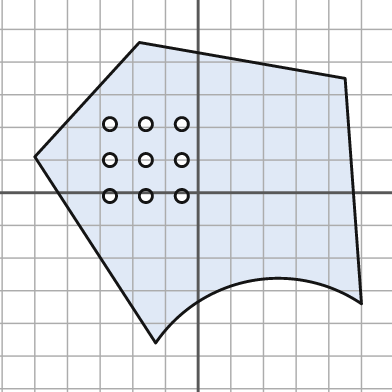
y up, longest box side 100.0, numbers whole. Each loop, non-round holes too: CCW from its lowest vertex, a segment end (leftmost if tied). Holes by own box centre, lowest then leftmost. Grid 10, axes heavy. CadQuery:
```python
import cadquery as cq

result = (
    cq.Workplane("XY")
    .moveTo(-13.0, -46.0)
    .threePointArc((16.0, -27.0), (50.0, -34.0))
    .lineTo(45.0, 35.0)
    .lineTo(-18.0, 46.0)
    .lineTo(-50.0, 11.0)
    .close()
    .moveTo(-27.0, -1.0)
    .circle(2.0)
    .moveTo(-16.0, -1.0)
    .circle(2.0)
    .moveTo(-5.0, -1.0)
    .circle(2.0)
    .moveTo(-27.0, 10.0)
    .circle(2.0)
    .moveTo(-16.0, 10.0)
    .circle(2.0)
    .moveTo(-5.0, 10.0)
    .circle(2.0)
    .moveTo(-27.0, 21.0)
    .circle(2.0)
    .moveTo(-16.0, 21.0)
    .circle(2.0)
    .moveTo(-5.0, 21.0)
    .circle(2.0)
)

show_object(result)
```